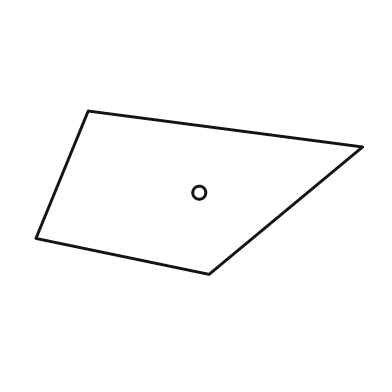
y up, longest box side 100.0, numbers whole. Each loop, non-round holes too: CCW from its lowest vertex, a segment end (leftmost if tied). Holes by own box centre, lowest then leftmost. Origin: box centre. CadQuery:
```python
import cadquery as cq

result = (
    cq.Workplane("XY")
    .moveTo(3.0, -25.0)
    .lineTo(50.0, 14.0)
    .lineTo(-34.0, 25.0)
    .lineTo(-50.0, -14.0)
    .close()
    .moveTo(0.0, 0.0)
    .circle(2.0)
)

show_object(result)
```